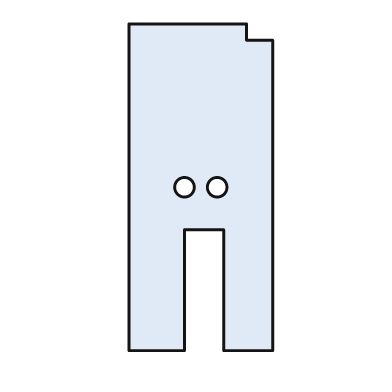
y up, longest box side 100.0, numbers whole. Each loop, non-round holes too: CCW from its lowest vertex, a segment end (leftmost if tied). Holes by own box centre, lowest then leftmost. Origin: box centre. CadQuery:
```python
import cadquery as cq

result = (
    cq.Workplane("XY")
    .moveTo(-22.0, -50.0)
    .lineTo(-5.0, -50.0)
    .lineTo(-5.0, -13.0)
    .lineTo(7.0, -13.0)
    .lineTo(7.0, -50.0)
    .lineTo(22.0, -50.0)
    .lineTo(22.0, 45.0)
    .lineTo(14.0, 45.0)
    .lineTo(14.0, 50.0)
    .lineTo(-22.0, 50.0)
    .close()
    .moveTo(-5.0, 0.0)
    .circle(3.0)
    .moveTo(5.0, 0.0)
    .circle(3.0)
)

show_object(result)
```